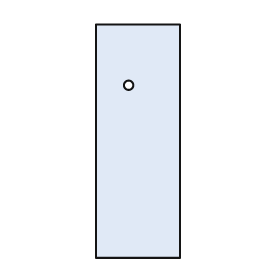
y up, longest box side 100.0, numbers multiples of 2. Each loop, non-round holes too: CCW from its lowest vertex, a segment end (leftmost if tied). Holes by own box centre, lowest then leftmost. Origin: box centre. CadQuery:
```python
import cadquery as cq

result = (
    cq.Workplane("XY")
    .moveTo(-18.0, -50.0)
    .lineTo(18.0, -50.0)
    .lineTo(18.0, 50.0)
    .lineTo(-18.0, 50.0)
    .close()
    .moveTo(-4.0, 24.0)
    .circle(2.0)
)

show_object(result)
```